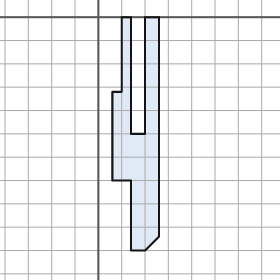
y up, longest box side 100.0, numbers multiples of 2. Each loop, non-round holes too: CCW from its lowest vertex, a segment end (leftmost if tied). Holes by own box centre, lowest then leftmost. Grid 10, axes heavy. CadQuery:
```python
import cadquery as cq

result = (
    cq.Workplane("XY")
    .moveTo(14.0, -100.0)
    .lineTo(20.0, -100.0)
    .lineTo(26.0, -94.0)
    .lineTo(26.0, 0.0)
    .lineTo(20.0, 0.0)
    .lineTo(20.0, -50.0)
    .lineTo(14.0, -50.0)
    .lineTo(14.0, 0.0)
    .lineTo(10.0, 0.0)
    .lineTo(10.0, -32.0)
    .lineTo(6.0, -32.0)
    .lineTo(6.0, -70.0)
    .lineTo(14.0, -70.0)
    .close()
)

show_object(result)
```